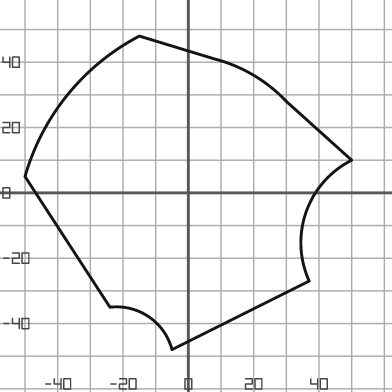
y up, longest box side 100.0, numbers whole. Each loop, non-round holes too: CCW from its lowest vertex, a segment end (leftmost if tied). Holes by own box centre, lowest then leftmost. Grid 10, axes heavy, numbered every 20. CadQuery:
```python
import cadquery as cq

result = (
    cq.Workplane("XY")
    .moveTo(-5.0, -48.0)
    .lineTo(37.0, -27.0)
    .threePointArc((36.0, -6.0), (50.0, 10.0))
    .lineTo(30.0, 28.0)
    .threePointArc((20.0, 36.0), (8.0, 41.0))
    .lineTo(-15.0, 48.0)
    .threePointArc((-37.0, 30.0), (-50.0, 5.0))
    .lineTo(-24.0, -35.0)
    .threePointArc((-12.0, -38.0), (-5.0, -48.0))
    .close()
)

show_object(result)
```